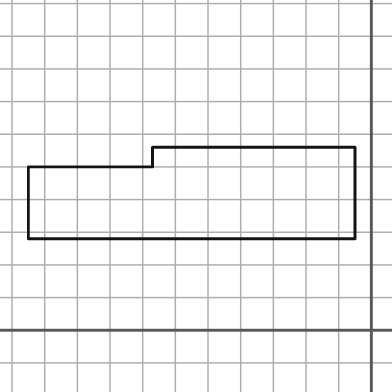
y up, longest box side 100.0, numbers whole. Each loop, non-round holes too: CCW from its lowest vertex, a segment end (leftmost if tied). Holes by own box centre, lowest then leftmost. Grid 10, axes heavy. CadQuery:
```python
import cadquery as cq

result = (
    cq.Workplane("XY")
    .moveTo(-105.0, 28.0)
    .lineTo(-5.0, 28.0)
    .lineTo(-5.0, 56.0)
    .lineTo(-67.0, 56.0)
    .lineTo(-67.0, 50.0)
    .lineTo(-105.0, 50.0)
    .close()
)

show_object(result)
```